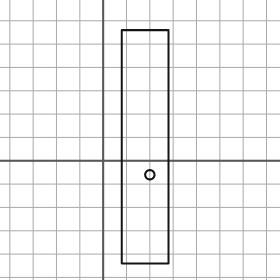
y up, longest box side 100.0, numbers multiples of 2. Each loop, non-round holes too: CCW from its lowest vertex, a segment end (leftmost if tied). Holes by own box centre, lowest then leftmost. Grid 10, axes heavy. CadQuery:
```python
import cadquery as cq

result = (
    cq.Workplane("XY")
    .moveTo(8.0, -44.0)
    .lineTo(28.0, -44.0)
    .lineTo(28.0, 56.0)
    .lineTo(8.0, 56.0)
    .close()
    .moveTo(20.0, -6.0)
    .circle(2.0)
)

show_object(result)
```